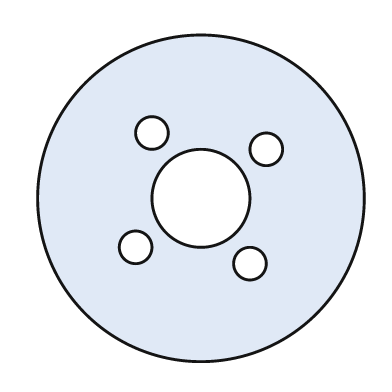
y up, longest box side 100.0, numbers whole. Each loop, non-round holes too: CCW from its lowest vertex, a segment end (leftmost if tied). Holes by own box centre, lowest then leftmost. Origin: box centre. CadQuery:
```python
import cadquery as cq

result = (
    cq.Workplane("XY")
    .moveTo(0.0, 0.0)
    .circle(50.0)
    .moveTo(15.0, -20.0)
    .circle(5.0)
    .moveTo(-20.0, -15.0)
    .circle(5.0)
    .moveTo(0.0, 0.0)
    .circle(15.0)
    .moveTo(20.0, 15.0)
    .circle(5.0)
    .moveTo(-15.0, 20.0)
    .circle(5.0)
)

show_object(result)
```